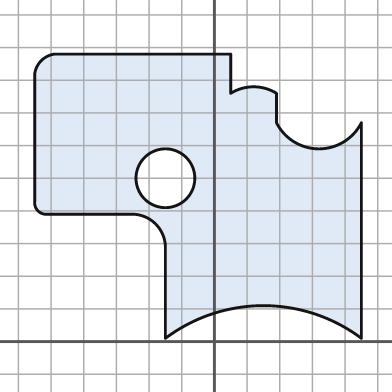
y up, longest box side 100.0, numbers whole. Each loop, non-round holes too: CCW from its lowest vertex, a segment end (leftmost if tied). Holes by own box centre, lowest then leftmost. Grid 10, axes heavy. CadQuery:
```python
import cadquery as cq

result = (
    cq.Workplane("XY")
    .moveTo(-15.0, 1.0)
    .threePointArc((15.0, 11.0), (45.0, 1.0))
    .lineTo(45.0, 67.0)
    .threePointArc((32.0, 59.0), (19.0, 67.0))
    .lineTo(19.0, 76.0)
    .threePointArc((12.0, 78.0), (5.0, 76.0))
    .lineTo(5.0, 88.0)
    .lineTo(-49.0, 88.0)
    .threePointArc((-53.0, 86.0), (-55.0, 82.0))
    .lineTo(-55.0, 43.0)
    .threePointArc((-54.0, 40.0), (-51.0, 39.0))
    .lineTo(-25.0, 39.0)
    .threePointArc((-18.0, 36.0), (-15.0, 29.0))
    .close()
    .moveTo(-15.0, 50.0)
    .circle(9.0)
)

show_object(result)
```